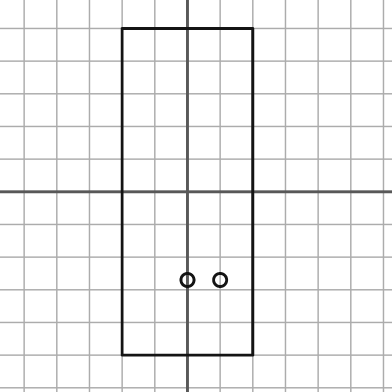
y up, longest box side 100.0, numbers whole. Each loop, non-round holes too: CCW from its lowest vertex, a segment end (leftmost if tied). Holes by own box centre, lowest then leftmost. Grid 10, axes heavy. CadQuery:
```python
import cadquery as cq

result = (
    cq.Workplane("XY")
    .moveTo(-20.0, -50.0)
    .lineTo(20.0, -50.0)
    .lineTo(20.0, 50.0)
    .lineTo(-20.0, 50.0)
    .close()
    .moveTo(0.0, -27.0)
    .circle(2.0)
    .moveTo(10.0, -27.0)
    .circle(2.0)
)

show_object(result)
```